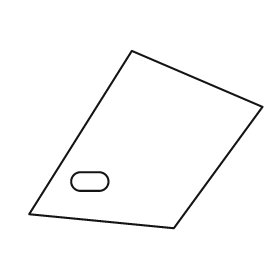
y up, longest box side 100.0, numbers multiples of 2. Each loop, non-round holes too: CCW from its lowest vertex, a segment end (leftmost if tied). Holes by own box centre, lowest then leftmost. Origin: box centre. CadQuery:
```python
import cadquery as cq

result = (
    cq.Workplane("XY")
    .moveTo(12.0, -38.0)
    .lineTo(50.0, 14.0)
    .lineTo(-6.0, 38.0)
    .lineTo(-50.0, -32.0)
    .close()
    .moveTo(-28.0, -22.0)
    .lineTo(-20.0, -22.0)
    .threePointArc((-16.0, -18.0), (-20.0, -14.0))
    .lineTo(-28.0, -14.0)
    .threePointArc((-32.0, -18.0), (-28.0, -22.0))
    .close()
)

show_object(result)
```